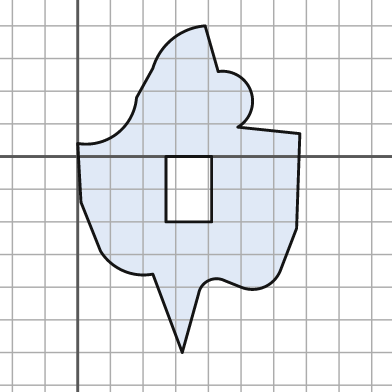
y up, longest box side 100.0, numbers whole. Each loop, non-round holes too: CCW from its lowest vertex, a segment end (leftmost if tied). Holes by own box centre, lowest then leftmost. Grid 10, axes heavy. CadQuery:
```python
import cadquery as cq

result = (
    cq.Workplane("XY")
    .moveTo(32.0, -60.0)
    .lineTo(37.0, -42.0)
    .threePointArc((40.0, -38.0), (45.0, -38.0))
    .lineTo(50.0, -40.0)
    .threePointArc((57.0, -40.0), (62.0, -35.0))
    .lineTo(67.0, -22.0)
    .lineTo(68.0, 7.0)
    .lineTo(49.0, 9.0)
    .threePointArc((53.0, 20.0), (43.0, 26.0))
    .lineTo(39.0, 40.0)
    .threePointArc((29.0, 36.0), (23.0, 27.0))
    .lineTo(18.0, 18.0)
    .threePointArc((12.0, 7.0), (0.0, 4.0))
    .lineTo(1.0, -14.0)
    .lineTo(7.0, -29.0)
    .threePointArc((14.0, -35.0), (23.0, -36.0))
    .close()
    .moveTo(27.0, -20.0)
    .lineTo(41.0, -20.0)
    .lineTo(41.0, 0.0)
    .lineTo(27.0, 0.0)
    .close()
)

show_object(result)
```